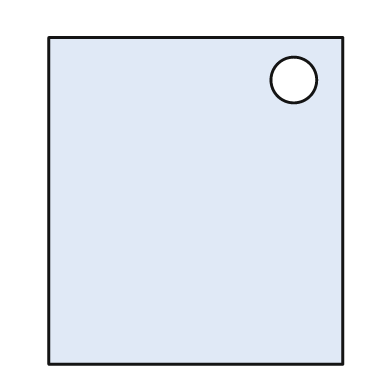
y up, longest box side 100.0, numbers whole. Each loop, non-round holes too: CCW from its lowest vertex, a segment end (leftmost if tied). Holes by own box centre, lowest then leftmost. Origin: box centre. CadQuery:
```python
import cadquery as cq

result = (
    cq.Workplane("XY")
    .moveTo(-45.0, -50.0)
    .lineTo(45.0, -50.0)
    .lineTo(45.0, 50.0)
    .lineTo(-45.0, 50.0)
    .close()
    .moveTo(30.0, 37.0)
    .circle(7.0)
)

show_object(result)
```